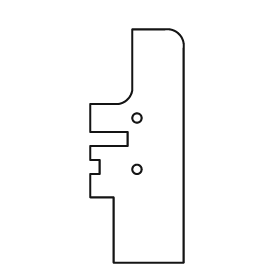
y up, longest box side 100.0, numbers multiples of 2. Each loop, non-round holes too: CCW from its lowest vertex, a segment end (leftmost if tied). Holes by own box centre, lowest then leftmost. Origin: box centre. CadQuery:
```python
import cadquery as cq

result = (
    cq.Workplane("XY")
    .moveTo(-10.0, -50.0)
    .lineTo(20.0, -50.0)
    .lineTo(20.0, 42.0)
    .threePointArc((18.0, 48.0), (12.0, 50.0))
    .lineTo(-2.0, 50.0)
    .lineTo(-2.0, 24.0)
    .threePointArc((-4.0, 20.0), (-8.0, 18.0))
    .lineTo(-20.0, 18.0)
    .lineTo(-20.0, 6.0)
    .lineTo(-4.0, 6.0)
    .lineTo(-4.0, 0.0)
    .lineTo(-20.0, 0.0)
    .lineTo(-20.0, -6.0)
    .lineTo(-16.0, -6.0)
    .lineTo(-16.0, -12.0)
    .lineTo(-20.0, -12.0)
    .lineTo(-20.0, -22.0)
    .lineTo(-10.0, -22.0)
    .close()
    .moveTo(0.0, -10.0)
    .circle(2.0)
    .moveTo(0.0, 12.0)
    .circle(2.0)
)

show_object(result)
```